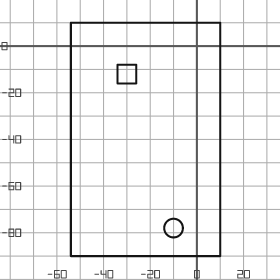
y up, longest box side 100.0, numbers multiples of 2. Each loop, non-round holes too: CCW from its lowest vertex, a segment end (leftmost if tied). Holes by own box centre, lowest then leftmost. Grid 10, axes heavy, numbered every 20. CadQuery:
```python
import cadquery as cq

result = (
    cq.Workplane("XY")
    .moveTo(-54.0, -90.0)
    .lineTo(10.0, -90.0)
    .lineTo(10.0, 10.0)
    .lineTo(-54.0, 10.0)
    .close()
    .moveTo(-10.0, -78.0)
    .circle(4.0)
    .moveTo(-34.0, -16.0)
    .lineTo(-26.0, -16.0)
    .lineTo(-26.0, -8.0)
    .lineTo(-34.0, -8.0)
    .close()
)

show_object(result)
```